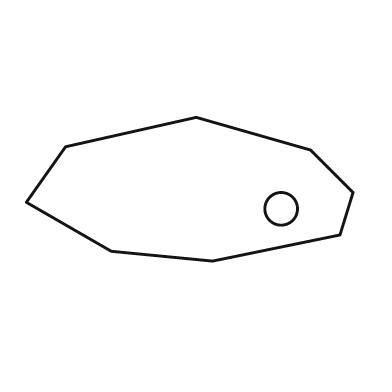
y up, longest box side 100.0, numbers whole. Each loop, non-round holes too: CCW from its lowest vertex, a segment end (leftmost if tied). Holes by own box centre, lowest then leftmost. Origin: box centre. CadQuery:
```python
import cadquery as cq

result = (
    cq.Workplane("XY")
    .moveTo(7.0, -22.0)
    .lineTo(46.0, -14.0)
    .lineTo(50.0, -1.0)
    .lineTo(37.0, 12.0)
    .lineTo(2.0, 22.0)
    .lineTo(-38.0, 13.0)
    .lineTo(-50.0, -4.0)
    .lineTo(-24.0, -19.0)
    .close()
    .moveTo(28.0, -6.0)
    .circle(5.0)
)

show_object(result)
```